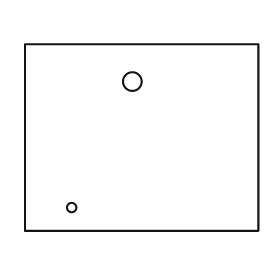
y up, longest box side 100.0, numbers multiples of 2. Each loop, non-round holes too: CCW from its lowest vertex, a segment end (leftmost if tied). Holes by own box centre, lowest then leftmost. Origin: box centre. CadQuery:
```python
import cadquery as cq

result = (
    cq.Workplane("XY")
    .moveTo(-50.0, -40.0)
    .lineTo(50.0, -40.0)
    .lineTo(50.0, 40.0)
    .lineTo(-50.0, 40.0)
    .close()
    .moveTo(-30.0, -30.0)
    .circle(2.0)
    .moveTo(-4.0, 24.0)
    .circle(4.0)
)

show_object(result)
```